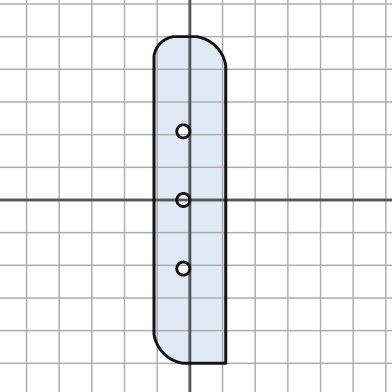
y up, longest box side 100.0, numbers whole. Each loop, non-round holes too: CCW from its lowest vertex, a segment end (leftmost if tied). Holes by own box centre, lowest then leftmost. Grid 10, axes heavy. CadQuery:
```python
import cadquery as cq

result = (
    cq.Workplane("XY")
    .moveTo(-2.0, -50.0)
    .lineTo(11.0, -50.0)
    .lineTo(11.0, 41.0)
    .threePointArc((8.0, 47.0), (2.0, 50.0))
    .lineTo(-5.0, 50.0)
    .threePointArc((-9.0, 48.0), (-11.0, 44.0))
    .lineTo(-11.0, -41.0)
    .threePointArc((-8.0, -47.0), (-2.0, -50.0))
    .close()
    .moveTo(-2.0, -21.0)
    .circle(2.0)
    .moveTo(-2.0, 0.0)
    .circle(2.0)
    .moveTo(-2.0, 21.0)
    .circle(2.0)
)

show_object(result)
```